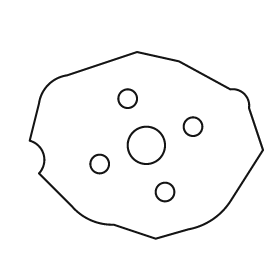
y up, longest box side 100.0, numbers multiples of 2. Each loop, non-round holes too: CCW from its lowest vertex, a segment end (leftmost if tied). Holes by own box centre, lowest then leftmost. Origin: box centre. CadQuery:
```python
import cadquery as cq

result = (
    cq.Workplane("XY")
    .moveTo(4.0, -40.0)
    .lineTo(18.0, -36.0)
    .threePointArc((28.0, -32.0), (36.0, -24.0))
    .lineTo(50.0, -2.0)
    .lineTo(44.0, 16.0)
    .threePointArc((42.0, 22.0), (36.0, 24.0))
    .lineTo(14.0, 36.0)
    .lineTo(-4.0, 40.0)
    .lineTo(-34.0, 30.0)
    .threePointArc((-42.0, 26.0), (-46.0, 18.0))
    .lineTo(-50.0, 2.0)
    .threePointArc((-44.0, -4.0), (-46.0, -12.0))
    .lineTo(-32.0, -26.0)
    .threePointArc((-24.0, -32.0), (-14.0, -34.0))
    .close()
    .moveTo(8.0, -20.0)
    .circle(4.0)
    .moveTo(-20.0, -8.0)
    .circle(4.0)
    .moveTo(0.0, 0.0)
    .circle(8.0)
    .moveTo(20.0, 8.0)
    .circle(4.0)
    .moveTo(-8.0, 20.0)
    .circle(4.0)
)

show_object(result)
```